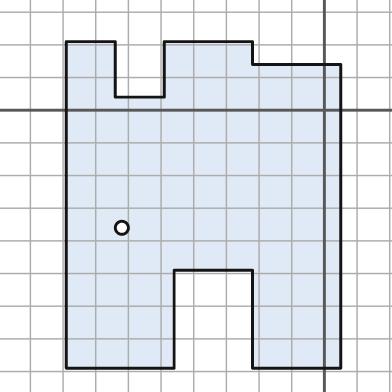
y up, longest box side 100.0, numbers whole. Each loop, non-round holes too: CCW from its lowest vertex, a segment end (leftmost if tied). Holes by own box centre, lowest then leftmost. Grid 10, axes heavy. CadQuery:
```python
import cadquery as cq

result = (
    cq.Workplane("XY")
    .moveTo(-79.0, -79.0)
    .lineTo(-46.0, -79.0)
    .lineTo(-46.0, -49.0)
    .lineTo(-22.0, -49.0)
    .lineTo(-22.0, -79.0)
    .lineTo(5.0, -79.0)
    .lineTo(5.0, 14.0)
    .lineTo(-22.0, 14.0)
    .lineTo(-22.0, 21.0)
    .lineTo(-49.0, 21.0)
    .lineTo(-49.0, 4.0)
    .lineTo(-64.0, 4.0)
    .lineTo(-64.0, 21.0)
    .lineTo(-79.0, 21.0)
    .close()
    .moveTo(-62.0, -36.0)
    .circle(2.0)
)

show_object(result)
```